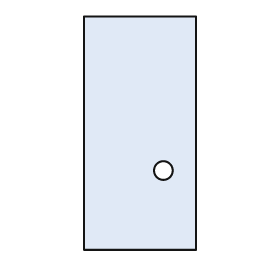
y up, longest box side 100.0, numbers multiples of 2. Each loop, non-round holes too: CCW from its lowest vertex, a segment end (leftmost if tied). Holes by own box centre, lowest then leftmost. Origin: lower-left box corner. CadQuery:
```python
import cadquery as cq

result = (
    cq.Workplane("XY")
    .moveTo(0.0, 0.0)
    .lineTo(48.0, 0.0)
    .lineTo(48.0, 100.0)
    .lineTo(0.0, 100.0)
    .close()
    .moveTo(34.0, 34.0)
    .circle(4.0)
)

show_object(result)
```